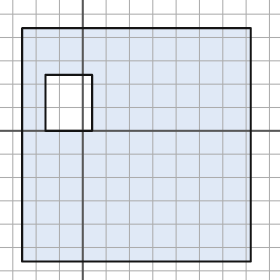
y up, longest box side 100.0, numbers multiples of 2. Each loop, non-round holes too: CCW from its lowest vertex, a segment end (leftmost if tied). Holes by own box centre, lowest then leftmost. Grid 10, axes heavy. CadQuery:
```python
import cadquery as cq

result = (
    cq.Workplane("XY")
    .moveTo(-26.0, -56.0)
    .lineTo(72.0, -56.0)
    .lineTo(72.0, 44.0)
    .lineTo(-26.0, 44.0)
    .close()
    .moveTo(-16.0, 0.0)
    .lineTo(4.0, 0.0)
    .lineTo(4.0, 24.0)
    .lineTo(-16.0, 24.0)
    .close()
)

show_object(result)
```